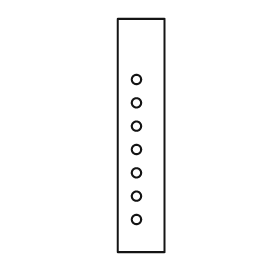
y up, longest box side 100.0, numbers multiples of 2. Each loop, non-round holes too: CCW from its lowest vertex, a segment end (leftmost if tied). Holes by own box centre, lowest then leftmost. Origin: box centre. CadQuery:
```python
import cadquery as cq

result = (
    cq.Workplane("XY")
    .moveTo(-10.0, -50.0)
    .lineTo(10.0, -50.0)
    .lineTo(10.0, 50.0)
    .lineTo(-10.0, 50.0)
    .close()
    .moveTo(-2.0, -36.0)
    .circle(2.0)
    .moveTo(-2.0, -26.0)
    .circle(2.0)
    .moveTo(-2.0, -16.0)
    .circle(2.0)
    .moveTo(-2.0, -6.0)
    .circle(2.0)
    .moveTo(-2.0, 4.0)
    .circle(2.0)
    .moveTo(-2.0, 14.0)
    .circle(2.0)
    .moveTo(-2.0, 24.0)
    .circle(2.0)
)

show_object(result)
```